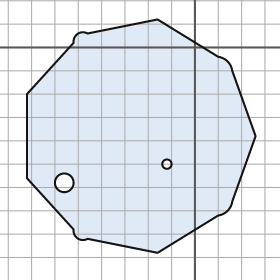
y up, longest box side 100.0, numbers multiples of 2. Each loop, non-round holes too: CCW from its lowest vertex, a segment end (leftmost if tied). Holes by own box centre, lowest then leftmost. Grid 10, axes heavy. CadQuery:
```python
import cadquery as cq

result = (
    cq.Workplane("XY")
    .moveTo(-16.0, -88.0)
    .lineTo(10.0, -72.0)
    .threePointArc((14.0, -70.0), (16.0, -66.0))
    .lineTo(26.0, -38.0)
    .lineTo(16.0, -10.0)
    .threePointArc((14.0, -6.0), (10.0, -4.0))
    .lineTo(-16.0, 12.0)
    .lineTo(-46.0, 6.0)
    .threePointArc((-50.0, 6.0), (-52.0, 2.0))
    .lineTo(-72.0, -20.0)
    .lineTo(-72.0, -56.0)
    .lineTo(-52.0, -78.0)
    .threePointArc((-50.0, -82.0), (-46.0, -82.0))
    .close()
    .moveTo(-56.0, -58.0)
    .circle(4.0)
    .moveTo(-12.0, -50.0)
    .circle(2.0)
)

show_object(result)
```